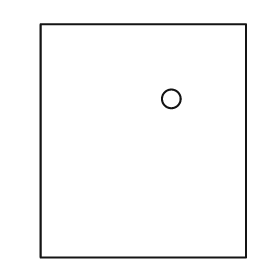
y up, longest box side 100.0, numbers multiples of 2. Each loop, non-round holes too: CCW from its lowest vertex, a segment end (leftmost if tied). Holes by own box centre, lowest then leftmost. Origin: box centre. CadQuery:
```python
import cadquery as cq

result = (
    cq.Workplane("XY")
    .moveTo(-44.0, -50.0)
    .lineTo(44.0, -50.0)
    .lineTo(44.0, 50.0)
    .lineTo(-44.0, 50.0)
    .close()
    .moveTo(12.0, 18.0)
    .circle(4.0)
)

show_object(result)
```